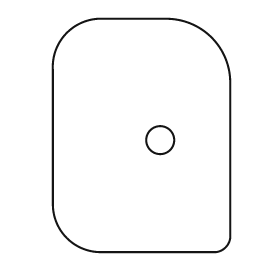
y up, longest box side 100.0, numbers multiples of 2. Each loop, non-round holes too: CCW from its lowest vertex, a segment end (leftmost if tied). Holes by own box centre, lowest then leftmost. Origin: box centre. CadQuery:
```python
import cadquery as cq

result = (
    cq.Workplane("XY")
    .moveTo(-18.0, -50.0)
    .lineTo(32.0, -50.0)
    .threePointArc((36.0, -48.0), (38.0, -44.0))
    .lineTo(38.0, 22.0)
    .threePointArc((30.0, 42.0), (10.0, 50.0))
    .lineTo(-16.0, 50.0)
    .threePointArc((-32.0, 44.0), (-38.0, 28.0))
    .lineTo(-38.0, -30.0)
    .threePointArc((-32.0, -44.0), (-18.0, -50.0))
    .close()
    .moveTo(8.0, -2.0)
    .circle(6.0)
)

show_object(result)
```